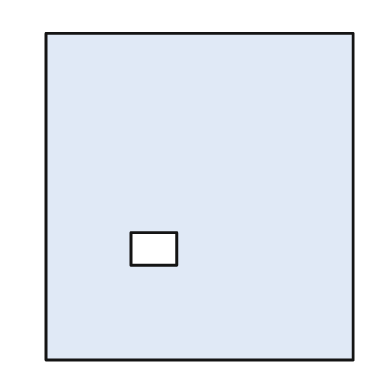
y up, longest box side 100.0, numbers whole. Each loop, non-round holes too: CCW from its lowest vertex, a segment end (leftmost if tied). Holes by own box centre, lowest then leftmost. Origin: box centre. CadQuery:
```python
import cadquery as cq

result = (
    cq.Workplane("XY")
    .moveTo(-47.0, -50.0)
    .lineTo(47.0, -50.0)
    .lineTo(47.0, 50.0)
    .lineTo(-47.0, 50.0)
    .close()
    .moveTo(-21.0, -21.0)
    .lineTo(-7.0, -21.0)
    .lineTo(-7.0, -11.0)
    .lineTo(-21.0, -11.0)
    .close()
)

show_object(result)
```